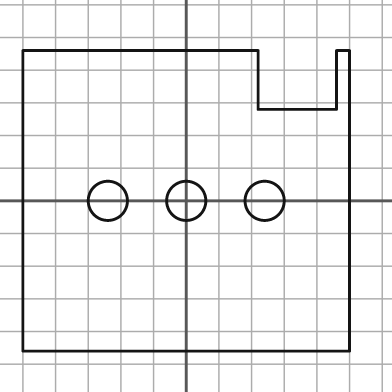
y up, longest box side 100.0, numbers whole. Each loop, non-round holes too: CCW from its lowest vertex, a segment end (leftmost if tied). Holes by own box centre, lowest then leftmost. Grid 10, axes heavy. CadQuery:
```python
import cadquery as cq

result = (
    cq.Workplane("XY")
    .moveTo(-50.0, -46.0)
    .lineTo(50.0, -46.0)
    .lineTo(50.0, 46.0)
    .lineTo(46.0, 46.0)
    .lineTo(46.0, 28.0)
    .lineTo(22.0, 28.0)
    .lineTo(22.0, 46.0)
    .lineTo(-50.0, 46.0)
    .close()
    .moveTo(-24.0, 0.0)
    .circle(6.0)
    .moveTo(0.0, 0.0)
    .circle(6.0)
    .moveTo(24.0, 0.0)
    .circle(6.0)
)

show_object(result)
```